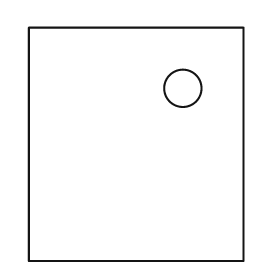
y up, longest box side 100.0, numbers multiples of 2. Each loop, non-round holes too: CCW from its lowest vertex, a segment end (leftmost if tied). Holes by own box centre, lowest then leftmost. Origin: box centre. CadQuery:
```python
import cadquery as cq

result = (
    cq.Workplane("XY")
    .moveTo(-46.0, -50.0)
    .lineTo(46.0, -50.0)
    .lineTo(46.0, 50.0)
    .lineTo(-46.0, 50.0)
    .close()
    .moveTo(20.0, 24.0)
    .circle(8.0)
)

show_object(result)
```